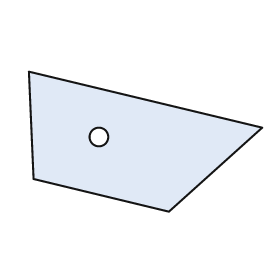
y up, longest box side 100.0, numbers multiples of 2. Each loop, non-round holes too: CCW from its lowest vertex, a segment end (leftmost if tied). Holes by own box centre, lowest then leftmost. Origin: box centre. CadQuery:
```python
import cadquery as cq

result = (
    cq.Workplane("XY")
    .moveTo(10.0, -30.0)
    .lineTo(50.0, 6.0)
    .lineTo(-50.0, 30.0)
    .lineTo(-48.0, -16.0)
    .close()
    .moveTo(-20.0, 2.0)
    .circle(4.0)
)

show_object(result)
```